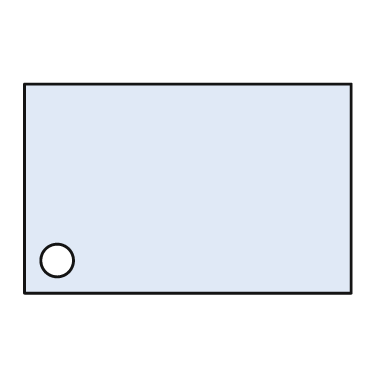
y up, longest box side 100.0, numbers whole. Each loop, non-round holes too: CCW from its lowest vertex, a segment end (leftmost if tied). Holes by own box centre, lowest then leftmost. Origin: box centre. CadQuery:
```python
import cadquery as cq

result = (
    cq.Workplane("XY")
    .moveTo(-50.0, -32.0)
    .lineTo(50.0, -32.0)
    .lineTo(50.0, 32.0)
    .lineTo(-50.0, 32.0)
    .close()
    .moveTo(-40.0, -22.0)
    .circle(5.0)
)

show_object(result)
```